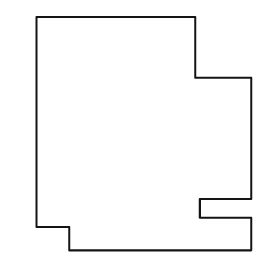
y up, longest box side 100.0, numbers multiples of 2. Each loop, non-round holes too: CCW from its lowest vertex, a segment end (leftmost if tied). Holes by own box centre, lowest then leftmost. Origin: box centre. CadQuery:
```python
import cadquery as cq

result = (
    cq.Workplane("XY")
    .moveTo(-32.0, -50.0)
    .lineTo(46.0, -50.0)
    .lineTo(46.0, -36.0)
    .lineTo(24.0, -36.0)
    .lineTo(24.0, -28.0)
    .lineTo(46.0, -28.0)
    .lineTo(46.0, 24.0)
    .lineTo(22.0, 24.0)
    .lineTo(22.0, 50.0)
    .lineTo(-46.0, 50.0)
    .lineTo(-46.0, -40.0)
    .lineTo(-32.0, -40.0)
    .close()
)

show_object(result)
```